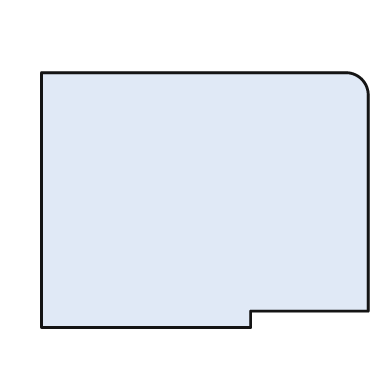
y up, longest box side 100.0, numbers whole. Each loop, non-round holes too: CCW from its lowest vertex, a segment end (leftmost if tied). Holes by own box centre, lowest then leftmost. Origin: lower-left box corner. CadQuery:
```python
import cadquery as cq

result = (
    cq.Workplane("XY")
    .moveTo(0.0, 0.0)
    .lineTo(64.0, 0.0)
    .lineTo(64.0, 5.0)
    .lineTo(100.0, 5.0)
    .lineTo(100.0, 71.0)
    .threePointArc((98.0, 76.0), (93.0, 78.0))
    .lineTo(0.0, 78.0)
    .close()
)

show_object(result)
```